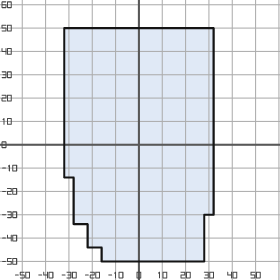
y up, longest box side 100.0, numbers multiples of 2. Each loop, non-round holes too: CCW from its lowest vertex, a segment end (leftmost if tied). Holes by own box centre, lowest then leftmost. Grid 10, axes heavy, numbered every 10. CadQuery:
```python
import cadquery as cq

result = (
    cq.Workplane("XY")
    .moveTo(-16.0, -50.0)
    .lineTo(28.0, -50.0)
    .lineTo(28.0, -30.0)
    .lineTo(32.0, -30.0)
    .lineTo(32.0, 50.0)
    .lineTo(-32.0, 50.0)
    .lineTo(-32.0, -14.0)
    .lineTo(-28.0, -14.0)
    .lineTo(-28.0, -34.0)
    .lineTo(-22.0, -34.0)
    .lineTo(-22.0, -44.0)
    .lineTo(-16.0, -44.0)
    .close()
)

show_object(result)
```